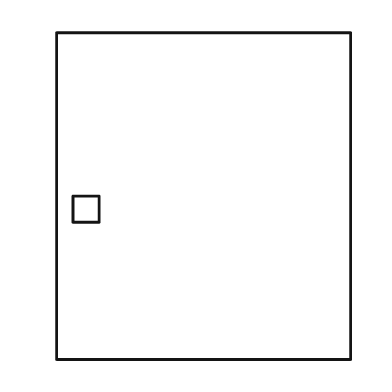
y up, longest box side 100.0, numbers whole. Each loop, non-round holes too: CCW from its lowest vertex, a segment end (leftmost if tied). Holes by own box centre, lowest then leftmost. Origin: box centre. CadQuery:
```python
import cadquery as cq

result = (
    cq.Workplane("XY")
    .moveTo(-45.0, -50.0)
    .lineTo(45.0, -50.0)
    .lineTo(45.0, 50.0)
    .lineTo(-45.0, 50.0)
    .close()
    .moveTo(-40.0, -8.0)
    .lineTo(-32.0, -8.0)
    .lineTo(-32.0, 0.0)
    .lineTo(-40.0, 0.0)
    .close()
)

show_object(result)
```